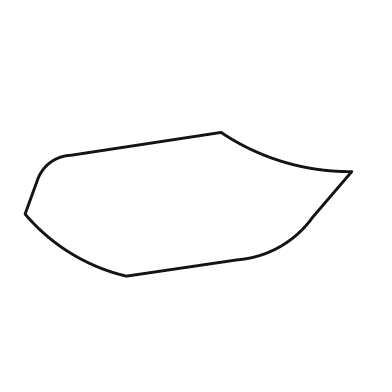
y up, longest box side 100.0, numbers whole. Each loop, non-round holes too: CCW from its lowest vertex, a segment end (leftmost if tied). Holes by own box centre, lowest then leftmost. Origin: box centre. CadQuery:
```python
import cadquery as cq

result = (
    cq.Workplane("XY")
    .moveTo(-19.0, -22.0)
    .lineTo(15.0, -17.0)
    .threePointArc((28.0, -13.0), (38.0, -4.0))
    .lineTo(50.0, 10.0)
    .threePointArc((29.0, 13.0), (10.0, 22.0))
    .lineTo(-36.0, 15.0)
    .threePointArc((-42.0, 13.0), (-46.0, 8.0))
    .lineTo(-50.0, -3.0)
    .threePointArc((-36.0, -15.0), (-19.0, -22.0))
    .close()
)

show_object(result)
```